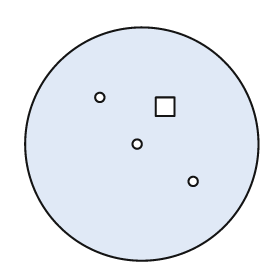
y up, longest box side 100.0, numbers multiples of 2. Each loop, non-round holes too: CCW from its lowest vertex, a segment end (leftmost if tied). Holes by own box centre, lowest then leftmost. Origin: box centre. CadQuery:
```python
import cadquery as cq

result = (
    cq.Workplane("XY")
    .moveTo(0.0, 0.0)
    .circle(50.0)
    .moveTo(22.0, -16.0)
    .circle(2.0)
    .moveTo(-2.0, 0.0)
    .circle(2.0)
    .moveTo(6.0, 12.0)
    .lineTo(14.0, 12.0)
    .lineTo(14.0, 20.0)
    .lineTo(6.0, 20.0)
    .close()
    .moveTo(-18.0, 20.0)
    .circle(2.0)
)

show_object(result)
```